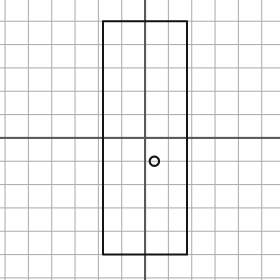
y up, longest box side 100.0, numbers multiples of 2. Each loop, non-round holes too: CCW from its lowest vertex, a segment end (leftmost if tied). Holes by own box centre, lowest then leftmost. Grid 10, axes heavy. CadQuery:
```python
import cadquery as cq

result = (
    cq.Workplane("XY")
    .moveTo(-18.0, -50.0)
    .lineTo(18.0, -50.0)
    .lineTo(18.0, 50.0)
    .lineTo(-18.0, 50.0)
    .close()
    .moveTo(4.0, -10.0)
    .circle(2.0)
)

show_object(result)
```